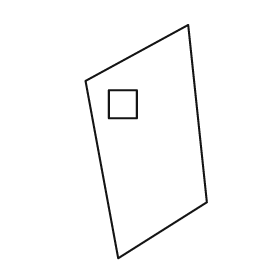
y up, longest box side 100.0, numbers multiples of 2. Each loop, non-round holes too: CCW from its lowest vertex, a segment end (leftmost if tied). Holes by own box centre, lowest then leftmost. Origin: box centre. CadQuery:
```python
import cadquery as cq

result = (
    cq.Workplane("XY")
    .moveTo(-12.0, -50.0)
    .lineTo(26.0, -26.0)
    .lineTo(18.0, 50.0)
    .lineTo(-26.0, 26.0)
    .close()
    .moveTo(-16.0, 10.0)
    .lineTo(-4.0, 10.0)
    .lineTo(-4.0, 22.0)
    .lineTo(-16.0, 22.0)
    .close()
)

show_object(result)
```